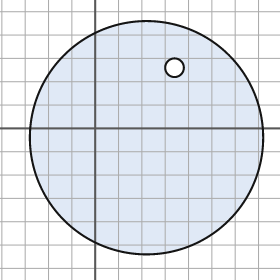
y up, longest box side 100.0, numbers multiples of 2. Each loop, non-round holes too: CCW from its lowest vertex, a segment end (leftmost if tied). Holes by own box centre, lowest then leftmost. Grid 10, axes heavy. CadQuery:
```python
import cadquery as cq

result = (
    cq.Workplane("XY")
    .moveTo(22.0, -4.0)
    .circle(50.0)
    .moveTo(34.0, 26.0)
    .circle(4.0)
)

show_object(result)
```